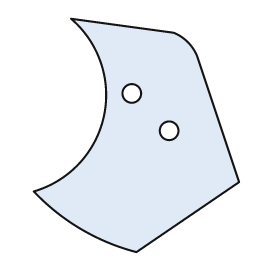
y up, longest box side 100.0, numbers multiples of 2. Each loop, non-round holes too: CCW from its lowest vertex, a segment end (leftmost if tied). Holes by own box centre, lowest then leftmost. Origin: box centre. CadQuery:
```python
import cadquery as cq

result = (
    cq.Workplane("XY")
    .moveTo(0.0, -50.0)
    .lineTo(44.0, -20.0)
    .lineTo(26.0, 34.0)
    .threePointArc((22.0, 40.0), (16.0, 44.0))
    .lineTo(-28.0, 50.0)
    .threePointArc((-14.0, 8.0), (-44.0, -24.0))
    .threePointArc((-24.0, -40.0), (0.0, -50.0))
    .close()
    .moveTo(14.0, 2.0)
    .circle(4.0)
    .moveTo(-2.0, 18.0)
    .circle(4.0)
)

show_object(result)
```